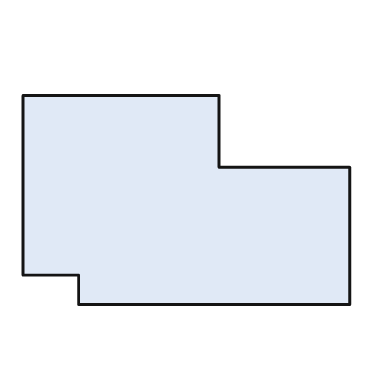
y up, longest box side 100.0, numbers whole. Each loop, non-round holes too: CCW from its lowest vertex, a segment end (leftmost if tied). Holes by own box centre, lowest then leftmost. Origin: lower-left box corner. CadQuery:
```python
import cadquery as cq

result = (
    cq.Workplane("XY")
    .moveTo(17.0, 0.0)
    .lineTo(100.0, 0.0)
    .lineTo(100.0, 42.0)
    .lineTo(60.0, 42.0)
    .lineTo(60.0, 64.0)
    .lineTo(0.0, 64.0)
    .lineTo(0.0, 9.0)
    .lineTo(17.0, 9.0)
    .close()
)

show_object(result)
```